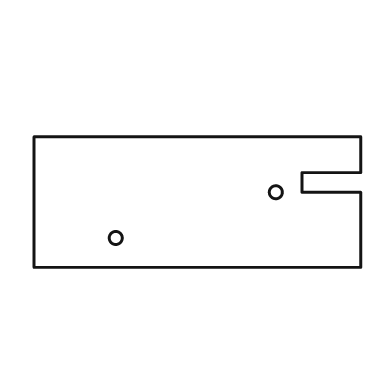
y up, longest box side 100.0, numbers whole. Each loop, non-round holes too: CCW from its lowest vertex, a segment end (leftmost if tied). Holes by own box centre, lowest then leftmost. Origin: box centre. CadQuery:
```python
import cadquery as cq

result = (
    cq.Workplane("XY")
    .moveTo(-50.0, -20.0)
    .lineTo(50.0, -20.0)
    .lineTo(50.0, 3.0)
    .lineTo(32.0, 3.0)
    .lineTo(32.0, 9.0)
    .lineTo(50.0, 9.0)
    .lineTo(50.0, 20.0)
    .lineTo(-50.0, 20.0)
    .close()
    .moveTo(-25.0, -11.0)
    .circle(2.0)
    .moveTo(24.0, 3.0)
    .circle(2.0)
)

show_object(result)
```